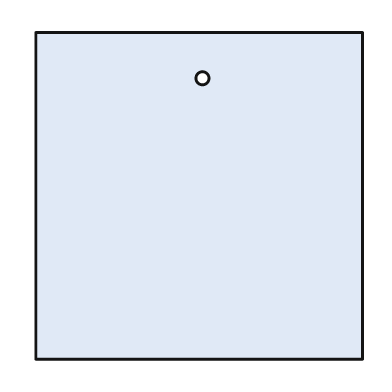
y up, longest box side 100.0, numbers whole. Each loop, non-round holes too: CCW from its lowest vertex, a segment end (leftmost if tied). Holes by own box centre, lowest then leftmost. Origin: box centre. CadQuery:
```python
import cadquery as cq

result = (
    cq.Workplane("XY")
    .moveTo(-50.0, -50.0)
    .lineTo(50.0, -50.0)
    .lineTo(50.0, 50.0)
    .lineTo(-50.0, 50.0)
    .close()
    .moveTo(1.0, 36.0)
    .circle(2.0)
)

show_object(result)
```